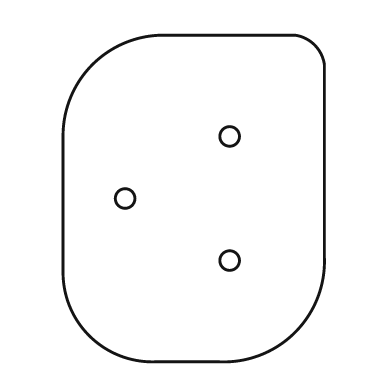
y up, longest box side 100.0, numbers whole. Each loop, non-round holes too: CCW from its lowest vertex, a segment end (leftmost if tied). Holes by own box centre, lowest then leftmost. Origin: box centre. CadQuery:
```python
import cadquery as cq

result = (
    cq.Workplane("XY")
    .moveTo(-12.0, -50.0)
    .lineTo(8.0, -50.0)
    .threePointArc((31.0, -41.0), (40.0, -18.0))
    .lineTo(40.0, 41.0)
    .threePointArc((37.0, 47.0), (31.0, 50.0))
    .lineTo(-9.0, 50.0)
    .threePointArc((-31.0, 41.0), (-40.0, 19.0))
    .lineTo(-40.0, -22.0)
    .threePointArc((-32.0, -42.0), (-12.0, -50.0))
    .close()
    .moveTo(11.0, -19.0)
    .circle(3.0)
    .moveTo(-21.0, 0.0)
    .circle(3.0)
    .moveTo(11.0, 19.0)
    .circle(3.0)
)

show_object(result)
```